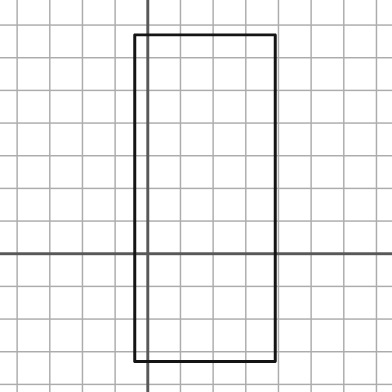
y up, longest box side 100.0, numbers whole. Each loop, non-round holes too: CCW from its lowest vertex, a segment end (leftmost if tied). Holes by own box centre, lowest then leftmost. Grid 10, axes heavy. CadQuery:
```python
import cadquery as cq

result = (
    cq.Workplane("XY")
    .moveTo(-4.0, -33.0)
    .lineTo(39.0, -33.0)
    .lineTo(39.0, 67.0)
    .lineTo(-4.0, 67.0)
    .close()
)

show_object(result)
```